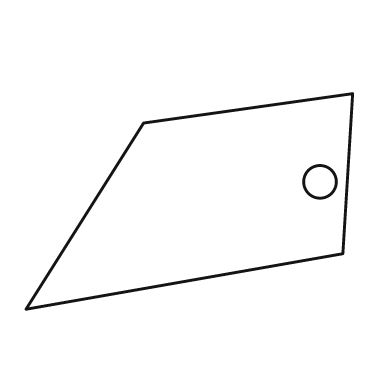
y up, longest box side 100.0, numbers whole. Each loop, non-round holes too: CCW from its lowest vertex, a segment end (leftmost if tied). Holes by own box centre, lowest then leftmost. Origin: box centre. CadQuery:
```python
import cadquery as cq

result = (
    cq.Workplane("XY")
    .moveTo(-50.0, -33.0)
    .lineTo(47.0, -16.0)
    .lineTo(50.0, 33.0)
    .lineTo(-14.0, 24.0)
    .close()
    .moveTo(40.0, 6.0)
    .circle(5.0)
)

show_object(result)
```